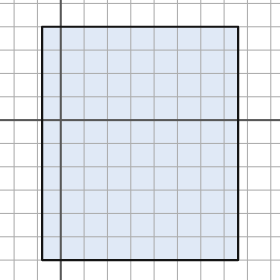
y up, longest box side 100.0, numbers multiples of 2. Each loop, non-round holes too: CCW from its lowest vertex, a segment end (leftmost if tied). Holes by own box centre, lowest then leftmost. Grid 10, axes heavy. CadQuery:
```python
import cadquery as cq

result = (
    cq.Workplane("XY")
    .moveTo(-8.0, -60.0)
    .lineTo(76.0, -60.0)
    .lineTo(76.0, 40.0)
    .lineTo(-8.0, 40.0)
    .close()
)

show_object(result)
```